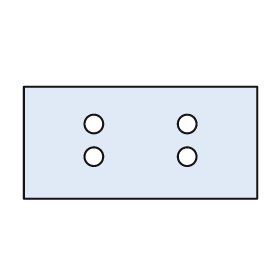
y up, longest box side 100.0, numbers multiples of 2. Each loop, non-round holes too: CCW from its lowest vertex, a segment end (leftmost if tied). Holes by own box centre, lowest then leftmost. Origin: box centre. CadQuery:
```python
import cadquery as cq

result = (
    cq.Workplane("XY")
    .moveTo(-50.0, -24.0)
    .lineTo(50.0, -24.0)
    .lineTo(50.0, 24.0)
    .lineTo(-50.0, 24.0)
    .close()
    .moveTo(-20.0, -6.0)
    .circle(4.0)
    .moveTo(20.0, -6.0)
    .circle(4.0)
    .moveTo(-20.0, 8.0)
    .circle(4.0)
    .moveTo(20.0, 8.0)
    .circle(4.0)
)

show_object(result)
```